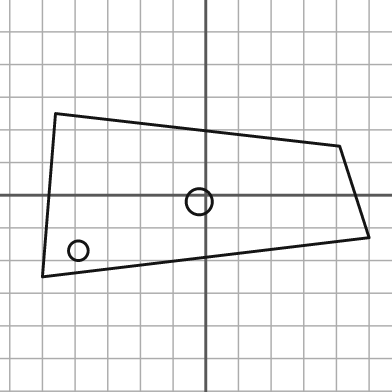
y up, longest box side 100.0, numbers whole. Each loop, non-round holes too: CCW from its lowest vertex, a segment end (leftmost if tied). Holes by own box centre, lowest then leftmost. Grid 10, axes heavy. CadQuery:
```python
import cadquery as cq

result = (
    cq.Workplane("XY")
    .moveTo(-50.0, -25.0)
    .lineTo(50.0, -13.0)
    .lineTo(41.0, 15.0)
    .lineTo(-46.0, 25.0)
    .close()
    .moveTo(-39.0, -17.0)
    .circle(3.0)
    .moveTo(-2.0, -2.0)
    .circle(4.0)
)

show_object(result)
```